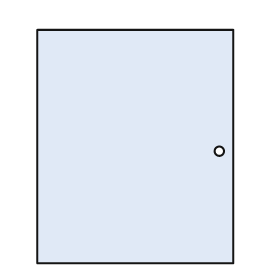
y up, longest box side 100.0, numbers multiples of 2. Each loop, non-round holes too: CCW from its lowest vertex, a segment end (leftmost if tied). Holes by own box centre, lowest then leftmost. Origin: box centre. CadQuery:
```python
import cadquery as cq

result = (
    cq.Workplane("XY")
    .moveTo(-42.0, -50.0)
    .lineTo(42.0, -50.0)
    .lineTo(42.0, 50.0)
    .lineTo(-42.0, 50.0)
    .close()
    .moveTo(36.0, -2.0)
    .circle(2.0)
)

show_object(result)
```